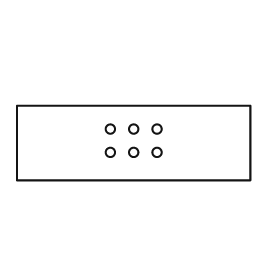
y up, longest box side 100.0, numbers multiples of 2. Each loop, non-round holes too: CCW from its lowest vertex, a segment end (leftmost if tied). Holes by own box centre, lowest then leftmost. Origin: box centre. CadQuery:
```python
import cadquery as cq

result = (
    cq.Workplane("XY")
    .moveTo(-50.0, -16.0)
    .lineTo(50.0, -16.0)
    .lineTo(50.0, 16.0)
    .lineTo(-50.0, 16.0)
    .close()
    .moveTo(-10.0, -4.0)
    .circle(2.0)
    .moveTo(0.0, -4.0)
    .circle(2.0)
    .moveTo(10.0, -4.0)
    .circle(2.0)
    .moveTo(-10.0, 6.0)
    .circle(2.0)
    .moveTo(0.0, 6.0)
    .circle(2.0)
    .moveTo(10.0, 6.0)
    .circle(2.0)
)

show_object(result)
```